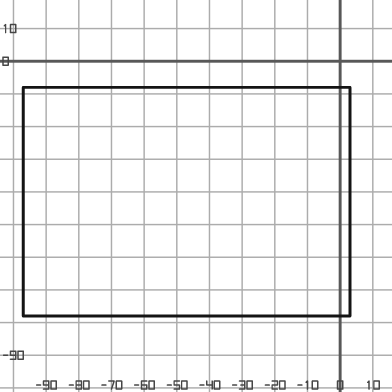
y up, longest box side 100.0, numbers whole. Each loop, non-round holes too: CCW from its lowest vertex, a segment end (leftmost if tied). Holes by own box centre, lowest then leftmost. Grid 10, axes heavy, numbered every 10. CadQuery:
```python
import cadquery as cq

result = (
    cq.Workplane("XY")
    .moveTo(-97.0, -78.0)
    .lineTo(3.0, -78.0)
    .lineTo(3.0, -8.0)
    .lineTo(-97.0, -8.0)
    .close()
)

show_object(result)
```